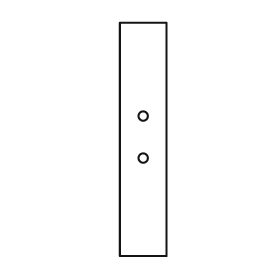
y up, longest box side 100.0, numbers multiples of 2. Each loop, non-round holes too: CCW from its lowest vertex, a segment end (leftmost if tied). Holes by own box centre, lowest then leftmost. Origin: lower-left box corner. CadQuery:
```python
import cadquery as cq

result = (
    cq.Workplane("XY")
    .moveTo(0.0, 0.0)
    .lineTo(20.0, 0.0)
    .lineTo(20.0, 100.0)
    .lineTo(0.0, 100.0)
    .close()
    .moveTo(10.0, 42.0)
    .circle(2.0)
    .moveTo(10.0, 60.0)
    .circle(2.0)
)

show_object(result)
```